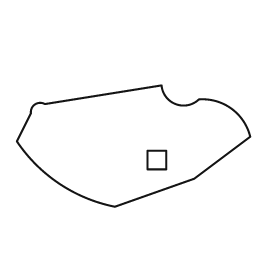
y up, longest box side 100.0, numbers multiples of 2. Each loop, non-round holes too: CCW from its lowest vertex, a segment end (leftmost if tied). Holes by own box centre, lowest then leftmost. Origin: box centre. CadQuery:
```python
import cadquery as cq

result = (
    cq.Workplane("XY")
    .moveTo(-8.0, -26.0)
    .lineTo(26.0, -14.0)
    .lineTo(50.0, 4.0)
    .threePointArc((42.0, 16.0), (28.0, 20.0))
    .threePointArc((18.0, 18.0), (12.0, 26.0))
    .lineTo(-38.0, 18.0)
    .threePointArc((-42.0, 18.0), (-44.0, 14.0))
    .lineTo(-50.0, 2.0)
    .threePointArc((-32.0, -16.0), (-8.0, -26.0))
    .close()
    .moveTo(6.0, -10.0)
    .lineTo(14.0, -10.0)
    .lineTo(14.0, -2.0)
    .lineTo(6.0, -2.0)
    .close()
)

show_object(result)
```